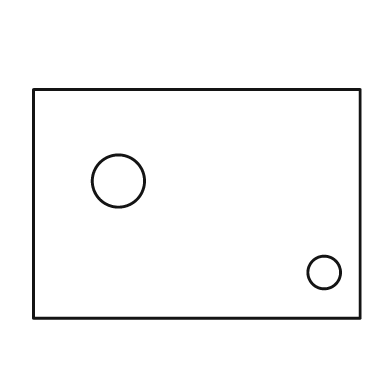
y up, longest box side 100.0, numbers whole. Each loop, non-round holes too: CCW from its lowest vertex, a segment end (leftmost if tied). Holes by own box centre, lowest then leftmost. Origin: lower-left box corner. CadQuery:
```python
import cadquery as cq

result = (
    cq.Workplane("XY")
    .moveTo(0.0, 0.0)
    .lineTo(100.0, 0.0)
    .lineTo(100.0, 70.0)
    .lineTo(0.0, 70.0)
    .close()
    .moveTo(89.0, 14.0)
    .circle(5.0)
    .moveTo(26.0, 42.0)
    .circle(8.0)
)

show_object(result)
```